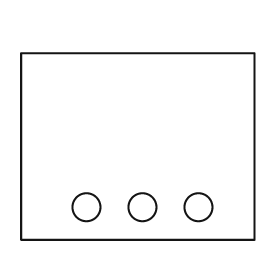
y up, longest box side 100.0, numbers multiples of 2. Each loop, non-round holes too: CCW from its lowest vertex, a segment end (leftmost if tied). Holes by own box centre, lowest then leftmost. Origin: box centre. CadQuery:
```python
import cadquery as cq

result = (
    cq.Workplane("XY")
    .moveTo(-50.0, -40.0)
    .lineTo(50.0, -40.0)
    .lineTo(50.0, 40.0)
    .lineTo(-50.0, 40.0)
    .close()
    .moveTo(-22.0, -26.0)
    .circle(6.0)
    .moveTo(2.0, -26.0)
    .circle(6.0)
    .moveTo(26.0, -26.0)
    .circle(6.0)
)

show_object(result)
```